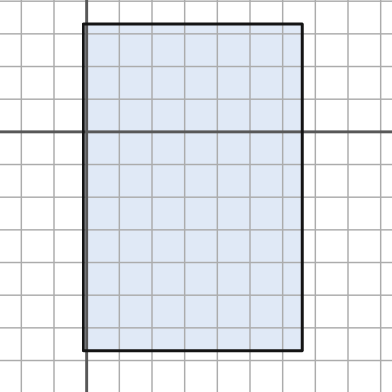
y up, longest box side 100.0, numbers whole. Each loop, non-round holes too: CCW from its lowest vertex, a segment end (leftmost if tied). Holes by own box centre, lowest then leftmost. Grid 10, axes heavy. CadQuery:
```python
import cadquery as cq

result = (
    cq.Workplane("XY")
    .moveTo(-1.0, -67.0)
    .lineTo(66.0, -67.0)
    .lineTo(66.0, 33.0)
    .lineTo(-1.0, 33.0)
    .close()
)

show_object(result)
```